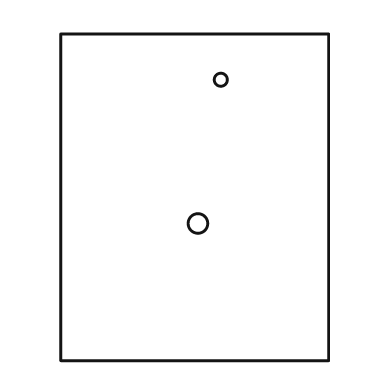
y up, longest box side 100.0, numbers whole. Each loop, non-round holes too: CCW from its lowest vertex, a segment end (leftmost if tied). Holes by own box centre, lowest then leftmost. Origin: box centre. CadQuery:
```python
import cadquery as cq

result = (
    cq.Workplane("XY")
    .moveTo(-41.0, -50.0)
    .lineTo(41.0, -50.0)
    .lineTo(41.0, 50.0)
    .lineTo(-41.0, 50.0)
    .close()
    .moveTo(1.0, -8.0)
    .circle(3.0)
    .moveTo(8.0, 36.0)
    .circle(2.0)
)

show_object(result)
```